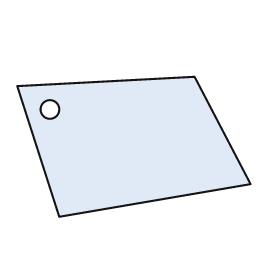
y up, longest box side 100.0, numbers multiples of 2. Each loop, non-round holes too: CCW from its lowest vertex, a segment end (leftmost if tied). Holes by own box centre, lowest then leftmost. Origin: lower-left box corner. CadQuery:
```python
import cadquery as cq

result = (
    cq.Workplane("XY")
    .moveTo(18.0, 0.0)
    .lineTo(100.0, 14.0)
    .lineTo(76.0, 60.0)
    .lineTo(0.0, 56.0)
    .close()
    .moveTo(14.0, 46.0)
    .circle(4.0)
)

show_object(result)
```